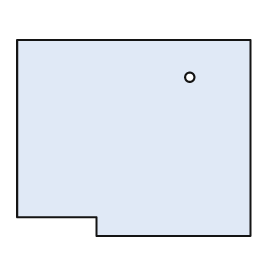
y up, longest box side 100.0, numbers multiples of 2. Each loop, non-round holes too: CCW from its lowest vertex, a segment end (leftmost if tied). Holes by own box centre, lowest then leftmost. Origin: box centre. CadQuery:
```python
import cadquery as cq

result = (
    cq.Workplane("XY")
    .moveTo(-16.0, -42.0)
    .lineTo(50.0, -42.0)
    .lineTo(50.0, 42.0)
    .lineTo(-50.0, 42.0)
    .lineTo(-50.0, -34.0)
    .lineTo(-16.0, -34.0)
    .close()
    .moveTo(24.0, 26.0)
    .circle(2.0)
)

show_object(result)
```